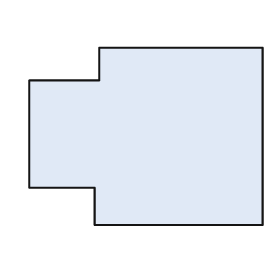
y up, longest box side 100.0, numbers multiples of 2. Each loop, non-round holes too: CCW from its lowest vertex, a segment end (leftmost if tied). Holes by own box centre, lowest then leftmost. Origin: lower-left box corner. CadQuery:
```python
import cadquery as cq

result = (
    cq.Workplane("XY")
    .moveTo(28.0, 0.0)
    .lineTo(100.0, 0.0)
    .lineTo(100.0, 76.0)
    .lineTo(30.0, 76.0)
    .lineTo(30.0, 62.0)
    .lineTo(0.0, 62.0)
    .lineTo(0.0, 16.0)
    .lineTo(28.0, 16.0)
    .close()
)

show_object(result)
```